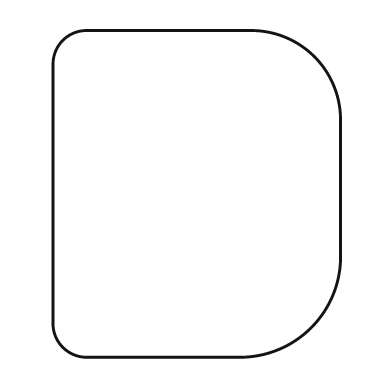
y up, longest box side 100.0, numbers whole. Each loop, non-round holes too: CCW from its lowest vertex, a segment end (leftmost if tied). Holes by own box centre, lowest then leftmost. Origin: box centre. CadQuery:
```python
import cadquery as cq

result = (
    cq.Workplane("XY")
    .moveTo(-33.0, -50.0)
    .lineTo(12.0, -50.0)
    .threePointArc((35.0, -41.0), (44.0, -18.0))
    .lineTo(44.0, 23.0)
    .threePointArc((36.0, 42.0), (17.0, 50.0))
    .lineTo(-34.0, 50.0)
    .threePointArc((-41.0, 47.0), (-44.0, 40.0))
    .lineTo(-44.0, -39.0)
    .threePointArc((-41.0, -47.0), (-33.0, -50.0))
    .close()
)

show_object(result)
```